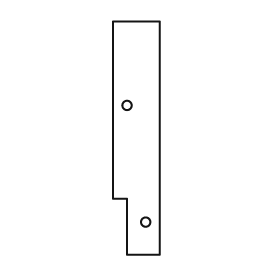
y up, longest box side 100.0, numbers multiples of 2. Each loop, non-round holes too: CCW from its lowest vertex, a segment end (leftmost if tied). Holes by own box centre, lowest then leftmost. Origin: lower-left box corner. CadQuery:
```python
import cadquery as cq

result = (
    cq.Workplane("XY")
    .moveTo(6.0, 0.0)
    .lineTo(20.0, 0.0)
    .lineTo(20.0, 100.0)
    .lineTo(0.0, 100.0)
    .lineTo(0.0, 24.0)
    .lineTo(6.0, 24.0)
    .close()
    .moveTo(14.0, 14.0)
    .circle(2.0)
    .moveTo(6.0, 64.0)
    .circle(2.0)
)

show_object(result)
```